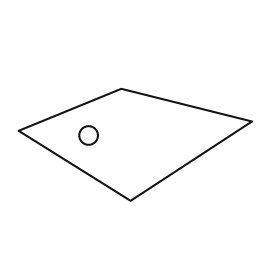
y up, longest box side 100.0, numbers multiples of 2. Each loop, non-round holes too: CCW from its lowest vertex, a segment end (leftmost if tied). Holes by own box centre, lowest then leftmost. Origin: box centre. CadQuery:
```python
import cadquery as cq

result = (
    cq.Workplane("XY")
    .moveTo(-2.0, -24.0)
    .lineTo(50.0, 10.0)
    .lineTo(-6.0, 24.0)
    .lineTo(-50.0, 6.0)
    .close()
    .moveTo(-20.0, 4.0)
    .circle(4.0)
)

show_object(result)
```